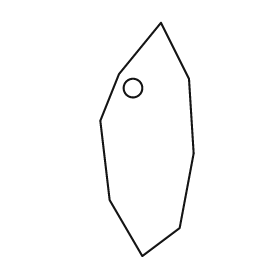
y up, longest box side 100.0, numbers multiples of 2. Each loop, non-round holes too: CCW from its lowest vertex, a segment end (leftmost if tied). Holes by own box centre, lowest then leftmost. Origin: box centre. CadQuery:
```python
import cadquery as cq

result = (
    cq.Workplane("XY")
    .moveTo(-2.0, -50.0)
    .lineTo(14.0, -38.0)
    .lineTo(20.0, -6.0)
    .lineTo(18.0, 26.0)
    .lineTo(6.0, 50.0)
    .lineTo(-12.0, 28.0)
    .lineTo(-20.0, 8.0)
    .lineTo(-16.0, -26.0)
    .close()
    .moveTo(-6.0, 22.0)
    .circle(4.0)
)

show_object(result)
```